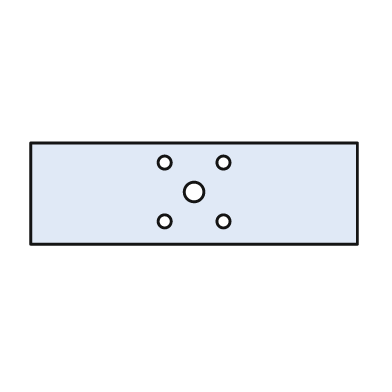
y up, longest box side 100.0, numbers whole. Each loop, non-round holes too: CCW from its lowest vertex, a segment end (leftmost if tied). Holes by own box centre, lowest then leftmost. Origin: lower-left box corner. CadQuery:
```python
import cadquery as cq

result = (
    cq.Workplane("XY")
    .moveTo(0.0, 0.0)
    .lineTo(100.0, 0.0)
    .lineTo(100.0, 31.0)
    .lineTo(0.0, 31.0)
    .close()
    .moveTo(41.0, 7.0)
    .circle(2.0)
    .moveTo(59.0, 7.0)
    .circle(2.0)
    .moveTo(50.0, 16.0)
    .circle(3.0)
    .moveTo(41.0, 25.0)
    .circle(2.0)
    .moveTo(59.0, 25.0)
    .circle(2.0)
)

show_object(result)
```